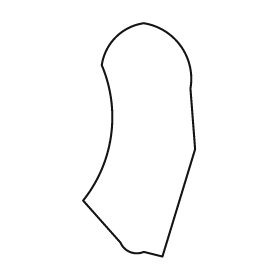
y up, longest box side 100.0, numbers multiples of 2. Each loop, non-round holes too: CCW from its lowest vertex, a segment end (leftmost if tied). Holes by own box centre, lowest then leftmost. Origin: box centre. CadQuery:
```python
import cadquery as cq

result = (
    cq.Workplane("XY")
    .moveTo(10.0, -50.0)
    .lineTo(24.0, -4.0)
    .lineTo(22.0, 22.0)
    .threePointArc((18.0, 40.0), (2.0, 50.0))
    .threePointArc((-10.0, 44.0), (-16.0, 32.0))
    .threePointArc((-12.0, 2.0), (-24.0, -26.0))
    .lineTo(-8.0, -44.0)
    .threePointArc((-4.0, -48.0), (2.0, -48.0))
    .close()
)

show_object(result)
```